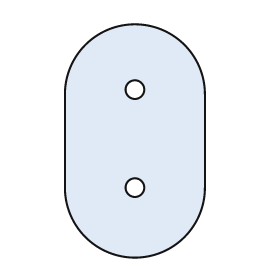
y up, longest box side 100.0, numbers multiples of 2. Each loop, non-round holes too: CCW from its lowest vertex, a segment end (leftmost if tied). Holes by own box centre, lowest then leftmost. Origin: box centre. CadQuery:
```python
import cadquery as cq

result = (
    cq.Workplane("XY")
    .moveTo(-30.0, -20.0)
    .threePointArc((0.0, -50.0), (30.0, -20.0))
    .lineTo(30.0, 20.0)
    .threePointArc((0.0, 50.0), (-30.0, 20.0))
    .close()
    .moveTo(0.0, -20.0)
    .circle(4.0)
    .moveTo(0.0, 22.0)
    .circle(4.0)
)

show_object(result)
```